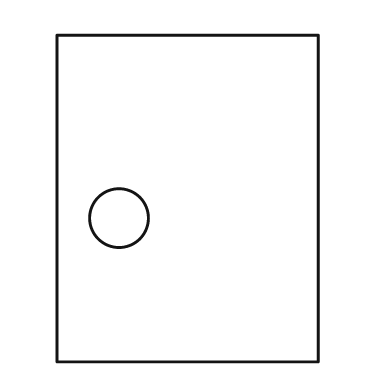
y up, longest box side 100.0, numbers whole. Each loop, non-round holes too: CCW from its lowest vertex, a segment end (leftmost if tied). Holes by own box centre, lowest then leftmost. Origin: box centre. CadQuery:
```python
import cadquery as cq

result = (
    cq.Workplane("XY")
    .moveTo(-40.0, -50.0)
    .lineTo(40.0, -50.0)
    .lineTo(40.0, 50.0)
    .lineTo(-40.0, 50.0)
    .close()
    .moveTo(-21.0, -6.0)
    .circle(9.0)
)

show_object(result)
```